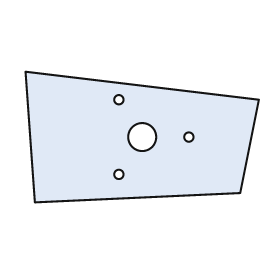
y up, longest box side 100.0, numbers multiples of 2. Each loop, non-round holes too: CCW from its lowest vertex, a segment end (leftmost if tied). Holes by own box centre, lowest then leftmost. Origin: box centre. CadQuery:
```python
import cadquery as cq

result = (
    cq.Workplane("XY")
    .moveTo(-46.0, -28.0)
    .lineTo(42.0, -24.0)
    .lineTo(50.0, 16.0)
    .lineTo(-50.0, 28.0)
    .close()
    .moveTo(-10.0, -16.0)
    .circle(2.0)
    .moveTo(0.0, 0.0)
    .circle(6.0)
    .moveTo(20.0, 0.0)
    .circle(2.0)
    .moveTo(-10.0, 16.0)
    .circle(2.0)
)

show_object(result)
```